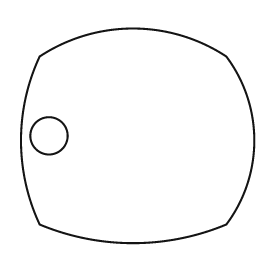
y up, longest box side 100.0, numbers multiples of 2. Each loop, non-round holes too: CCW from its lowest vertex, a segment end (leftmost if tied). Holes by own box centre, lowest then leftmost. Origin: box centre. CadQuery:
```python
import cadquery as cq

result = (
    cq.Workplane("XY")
    .moveTo(-42.0, -38.0)
    .threePointArc((-2.0, -46.0), (38.0, -38.0))
    .threePointArc((50.0, -2.0), (38.0, 34.0))
    .threePointArc((-2.0, 46.0), (-42.0, 34.0))
    .threePointArc((-50.0, -2.0), (-42.0, -38.0))
    .close()
    .moveTo(-38.0, 0.0)
    .circle(8.0)
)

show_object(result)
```